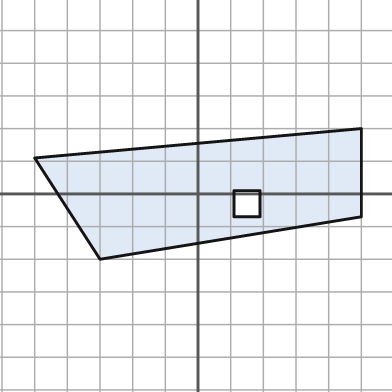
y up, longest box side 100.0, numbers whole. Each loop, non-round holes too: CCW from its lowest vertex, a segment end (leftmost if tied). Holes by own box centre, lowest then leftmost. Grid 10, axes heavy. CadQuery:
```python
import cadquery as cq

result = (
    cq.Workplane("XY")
    .moveTo(-30.0, -20.0)
    .lineTo(50.0, -7.0)
    .lineTo(50.0, 20.0)
    .lineTo(-50.0, 11.0)
    .close()
    .moveTo(11.0, -7.0)
    .lineTo(19.0, -7.0)
    .lineTo(19.0, 1.0)
    .lineTo(11.0, 1.0)
    .close()
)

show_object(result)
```